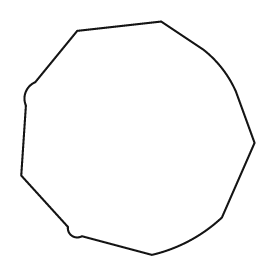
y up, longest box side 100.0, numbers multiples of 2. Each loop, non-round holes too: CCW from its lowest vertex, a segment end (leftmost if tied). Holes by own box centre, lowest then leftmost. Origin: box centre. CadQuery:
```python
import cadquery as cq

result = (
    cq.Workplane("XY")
    .moveTo(6.0, -50.0)
    .threePointArc((22.0, -44.0), (36.0, -34.0))
    .lineTo(50.0, -2.0)
    .lineTo(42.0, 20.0)
    .threePointArc((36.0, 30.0), (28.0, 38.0))
    .lineTo(10.0, 50.0)
    .lineTo(-26.0, 46.0)
    .lineTo(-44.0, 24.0)
    .threePointArc((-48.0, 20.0), (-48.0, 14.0))
    .lineTo(-50.0, -16.0)
    .lineTo(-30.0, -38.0)
    .threePointArc((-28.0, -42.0), (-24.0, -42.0))
    .close()
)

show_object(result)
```